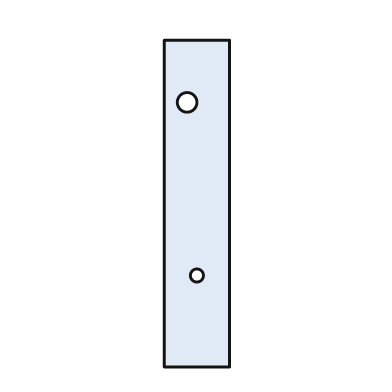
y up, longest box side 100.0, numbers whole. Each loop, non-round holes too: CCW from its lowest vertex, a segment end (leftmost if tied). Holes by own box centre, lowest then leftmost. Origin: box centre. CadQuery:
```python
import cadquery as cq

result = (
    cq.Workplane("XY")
    .moveTo(-10.0, -50.0)
    .lineTo(10.0, -50.0)
    .lineTo(10.0, 50.0)
    .lineTo(-10.0, 50.0)
    .close()
    .moveTo(0.0, -22.0)
    .circle(2.0)
    .moveTo(-3.0, 31.0)
    .circle(3.0)
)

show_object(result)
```